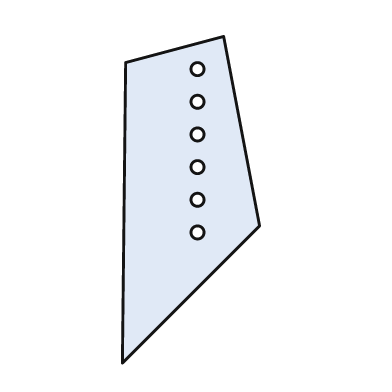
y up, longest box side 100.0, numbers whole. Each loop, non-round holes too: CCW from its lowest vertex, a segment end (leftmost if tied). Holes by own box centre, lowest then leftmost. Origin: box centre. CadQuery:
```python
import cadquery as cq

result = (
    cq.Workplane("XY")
    .moveTo(-21.0, -50.0)
    .lineTo(21.0, -8.0)
    .lineTo(10.0, 50.0)
    .lineTo(-20.0, 42.0)
    .close()
    .moveTo(2.0, -10.0)
    .circle(2.0)
    .moveTo(2.0, 0.0)
    .circle(2.0)
    .moveTo(2.0, 10.0)
    .circle(2.0)
    .moveTo(2.0, 20.0)
    .circle(2.0)
    .moveTo(2.0, 30.0)
    .circle(2.0)
    .moveTo(2.0, 40.0)
    .circle(2.0)
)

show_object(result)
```